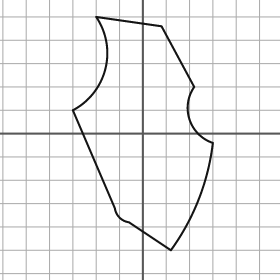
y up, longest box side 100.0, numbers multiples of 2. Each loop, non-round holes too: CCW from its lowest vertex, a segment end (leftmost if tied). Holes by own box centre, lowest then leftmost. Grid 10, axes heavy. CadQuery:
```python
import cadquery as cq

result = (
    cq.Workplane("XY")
    .moveTo(12.0, -50.0)
    .threePointArc((24.0, -28.0), (30.0, -4.0))
    .threePointArc((20.0, 6.0), (22.0, 20.0))
    .lineTo(8.0, 46.0)
    .lineTo(-20.0, 50.0)
    .threePointArc((-16.0, 28.0), (-30.0, 10.0))
    .lineTo(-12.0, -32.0)
    .threePointArc((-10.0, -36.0), (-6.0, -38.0))
    .close()
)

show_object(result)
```